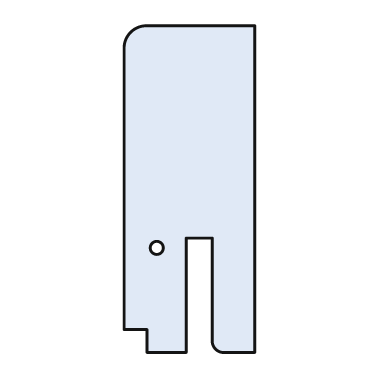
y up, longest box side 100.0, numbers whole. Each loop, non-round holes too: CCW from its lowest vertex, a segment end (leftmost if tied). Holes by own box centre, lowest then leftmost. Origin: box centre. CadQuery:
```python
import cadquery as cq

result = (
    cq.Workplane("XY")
    .moveTo(-13.0, -50.0)
    .lineTo(-1.0, -50.0)
    .lineTo(-1.0, -15.0)
    .lineTo(7.0, -15.0)
    .lineTo(7.0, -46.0)
    .threePointArc((8.0, -49.0), (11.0, -50.0))
    .lineTo(20.0, -50.0)
    .lineTo(20.0, 50.0)
    .lineTo(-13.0, 50.0)
    .threePointArc((-18.0, 48.0), (-20.0, 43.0))
    .lineTo(-20.0, -43.0)
    .lineTo(-13.0, -43.0)
    .close()
    .moveTo(-10.0, -18.0)
    .circle(2.0)
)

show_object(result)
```